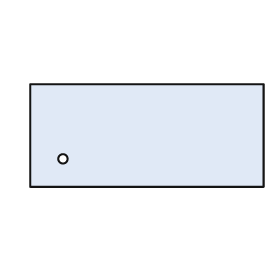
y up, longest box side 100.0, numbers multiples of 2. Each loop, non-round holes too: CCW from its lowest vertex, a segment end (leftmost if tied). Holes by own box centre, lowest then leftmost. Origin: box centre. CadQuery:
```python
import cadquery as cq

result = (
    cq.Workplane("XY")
    .moveTo(-50.0, -22.0)
    .lineTo(50.0, -22.0)
    .lineTo(50.0, 22.0)
    .lineTo(-50.0, 22.0)
    .close()
    .moveTo(-36.0, -10.0)
    .circle(2.0)
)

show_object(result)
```